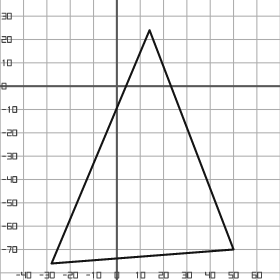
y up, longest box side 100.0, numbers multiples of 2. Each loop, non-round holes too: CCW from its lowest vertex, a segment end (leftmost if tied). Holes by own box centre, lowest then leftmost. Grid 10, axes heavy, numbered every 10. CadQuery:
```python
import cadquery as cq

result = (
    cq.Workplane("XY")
    .moveTo(-28.0, -76.0)
    .lineTo(50.0, -70.0)
    .lineTo(14.0, 24.0)
    .close()
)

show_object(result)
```